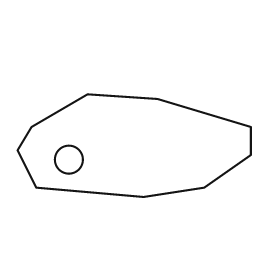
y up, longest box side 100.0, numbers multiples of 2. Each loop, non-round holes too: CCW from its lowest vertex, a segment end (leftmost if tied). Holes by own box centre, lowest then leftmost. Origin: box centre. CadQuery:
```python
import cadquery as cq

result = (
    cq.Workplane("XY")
    .moveTo(4.0, -22.0)
    .lineTo(30.0, -18.0)
    .lineTo(50.0, -4.0)
    .lineTo(50.0, 8.0)
    .lineTo(10.0, 20.0)
    .lineTo(-20.0, 22.0)
    .lineTo(-44.0, 8.0)
    .lineTo(-50.0, -2.0)
    .lineTo(-42.0, -18.0)
    .close()
    .moveTo(-28.0, -6.0)
    .circle(6.0)
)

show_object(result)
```